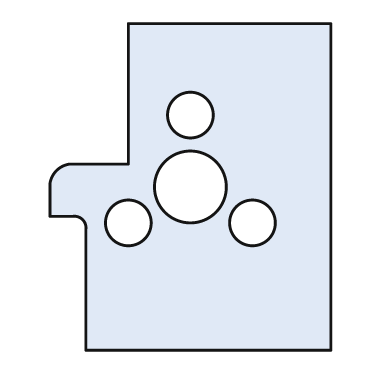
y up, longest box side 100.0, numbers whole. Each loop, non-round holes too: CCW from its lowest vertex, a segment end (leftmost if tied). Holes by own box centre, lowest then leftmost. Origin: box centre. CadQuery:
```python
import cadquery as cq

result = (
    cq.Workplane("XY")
    .moveTo(-32.0, -50.0)
    .lineTo(43.0, -50.0)
    .lineTo(43.0, 50.0)
    .lineTo(-19.0, 50.0)
    .lineTo(-19.0, 7.0)
    .lineTo(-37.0, 7.0)
    .threePointArc((-41.0, 5.0), (-43.0, 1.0))
    .lineTo(-43.0, -9.0)
    .lineTo(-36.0, -9.0)
    .threePointArc((-33.0, -10.0), (-32.0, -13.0))
    .close()
    .moveTo(-19.0, -11.0)
    .circle(7.0)
    .moveTo(19.0, -11.0)
    .circle(7.0)
    .moveTo(0.0, 0.0)
    .circle(11.0)
    .moveTo(0.0, 22.0)
    .circle(7.0)
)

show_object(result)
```